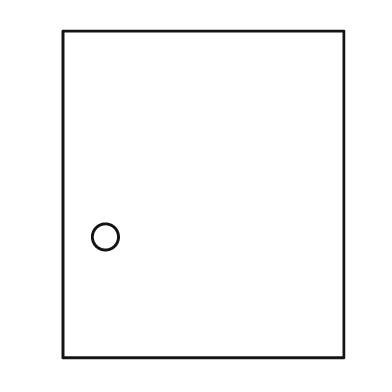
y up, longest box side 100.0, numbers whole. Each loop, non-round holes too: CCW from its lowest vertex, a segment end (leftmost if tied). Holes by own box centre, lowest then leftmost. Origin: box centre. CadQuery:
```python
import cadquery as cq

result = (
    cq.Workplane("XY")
    .moveTo(-43.0, -50.0)
    .lineTo(43.0, -50.0)
    .lineTo(43.0, 50.0)
    .lineTo(-43.0, 50.0)
    .close()
    .moveTo(-30.0, -13.0)
    .circle(4.0)
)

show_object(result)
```